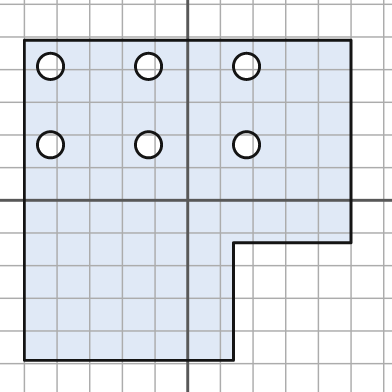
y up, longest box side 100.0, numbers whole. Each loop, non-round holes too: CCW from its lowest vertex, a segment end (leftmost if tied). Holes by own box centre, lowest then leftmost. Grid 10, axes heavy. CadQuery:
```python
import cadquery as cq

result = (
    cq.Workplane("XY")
    .moveTo(-50.0, -49.0)
    .lineTo(14.0, -49.0)
    .lineTo(14.0, -13.0)
    .lineTo(50.0, -13.0)
    .lineTo(50.0, 49.0)
    .lineTo(-50.0, 49.0)
    .close()
    .moveTo(-42.0, 17.0)
    .circle(4.0)
    .moveTo(-12.0, 17.0)
    .circle(4.0)
    .moveTo(18.0, 17.0)
    .circle(4.0)
    .moveTo(-42.0, 41.0)
    .circle(4.0)
    .moveTo(-12.0, 41.0)
    .circle(4.0)
    .moveTo(18.0, 41.0)
    .circle(4.0)
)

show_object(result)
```